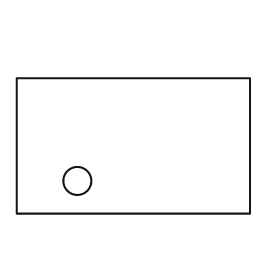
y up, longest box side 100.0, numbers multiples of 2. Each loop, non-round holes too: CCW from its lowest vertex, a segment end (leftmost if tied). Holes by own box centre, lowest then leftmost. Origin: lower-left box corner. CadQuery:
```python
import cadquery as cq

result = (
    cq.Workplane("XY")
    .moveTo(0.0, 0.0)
    .lineTo(100.0, 0.0)
    .lineTo(100.0, 58.0)
    .lineTo(0.0, 58.0)
    .close()
    .moveTo(26.0, 14.0)
    .circle(6.0)
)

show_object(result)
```